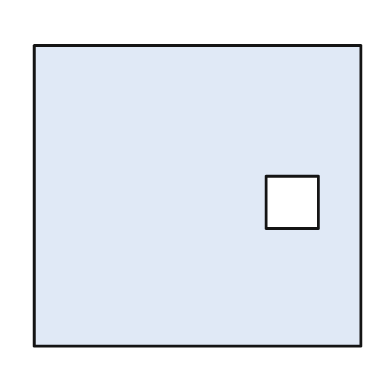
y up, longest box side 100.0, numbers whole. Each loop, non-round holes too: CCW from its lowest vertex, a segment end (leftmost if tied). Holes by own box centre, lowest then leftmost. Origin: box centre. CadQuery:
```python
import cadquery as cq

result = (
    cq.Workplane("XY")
    .moveTo(-50.0, -46.0)
    .lineTo(50.0, -46.0)
    .lineTo(50.0, 46.0)
    .lineTo(-50.0, 46.0)
    .close()
    .moveTo(21.0, -10.0)
    .lineTo(37.0, -10.0)
    .lineTo(37.0, 6.0)
    .lineTo(21.0, 6.0)
    .close()
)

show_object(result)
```